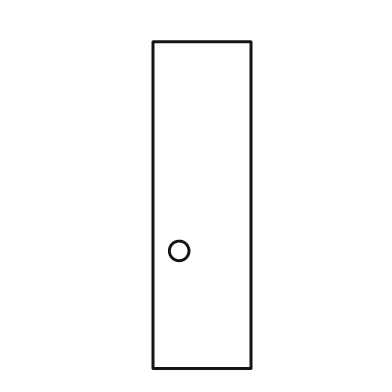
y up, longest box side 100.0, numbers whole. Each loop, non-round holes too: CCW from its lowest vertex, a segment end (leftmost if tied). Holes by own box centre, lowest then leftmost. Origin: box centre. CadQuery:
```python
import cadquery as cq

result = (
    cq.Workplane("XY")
    .moveTo(-15.0, -50.0)
    .lineTo(15.0, -50.0)
    .lineTo(15.0, 50.0)
    .lineTo(-15.0, 50.0)
    .close()
    .moveTo(-7.0, -14.0)
    .circle(3.0)
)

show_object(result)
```